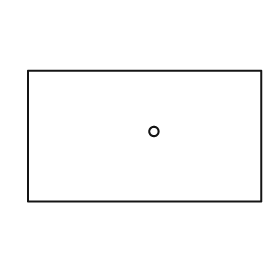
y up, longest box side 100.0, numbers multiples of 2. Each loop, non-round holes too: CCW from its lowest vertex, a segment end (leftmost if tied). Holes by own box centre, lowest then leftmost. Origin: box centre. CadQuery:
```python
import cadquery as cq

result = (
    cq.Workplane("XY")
    .moveTo(-50.0, -28.0)
    .lineTo(50.0, -28.0)
    .lineTo(50.0, 28.0)
    .lineTo(-50.0, 28.0)
    .close()
    .moveTo(4.0, 2.0)
    .circle(2.0)
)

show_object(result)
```